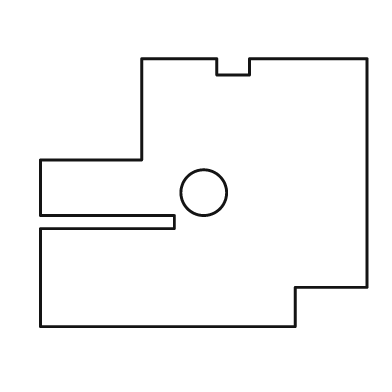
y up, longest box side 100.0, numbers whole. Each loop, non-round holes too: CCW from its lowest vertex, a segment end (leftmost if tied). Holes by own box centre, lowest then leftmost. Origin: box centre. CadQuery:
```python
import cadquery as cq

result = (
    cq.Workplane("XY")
    .moveTo(-50.0, -41.0)
    .lineTo(28.0, -41.0)
    .lineTo(28.0, -29.0)
    .lineTo(50.0, -29.0)
    .lineTo(50.0, 41.0)
    .lineTo(14.0, 41.0)
    .lineTo(14.0, 36.0)
    .lineTo(4.0, 36.0)
    .lineTo(4.0, 41.0)
    .lineTo(-19.0, 41.0)
    .lineTo(-19.0, 10.0)
    .lineTo(-50.0, 10.0)
    .lineTo(-50.0, -7.0)
    .lineTo(-9.0, -7.0)
    .lineTo(-9.0, -11.0)
    .lineTo(-50.0, -11.0)
    .close()
    .moveTo(0.0, 0.0)
    .circle(7.0)
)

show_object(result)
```